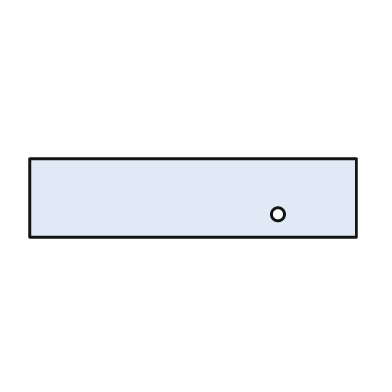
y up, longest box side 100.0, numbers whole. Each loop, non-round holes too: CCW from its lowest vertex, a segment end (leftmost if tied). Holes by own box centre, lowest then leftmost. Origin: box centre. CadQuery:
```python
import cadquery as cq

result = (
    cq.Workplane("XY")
    .moveTo(-50.0, -12.0)
    .lineTo(50.0, -12.0)
    .lineTo(50.0, 12.0)
    .lineTo(-50.0, 12.0)
    .close()
    .moveTo(26.0, -5.0)
    .circle(2.0)
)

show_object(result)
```